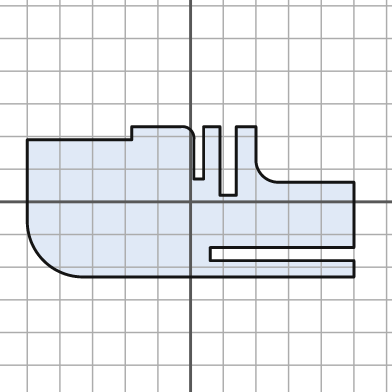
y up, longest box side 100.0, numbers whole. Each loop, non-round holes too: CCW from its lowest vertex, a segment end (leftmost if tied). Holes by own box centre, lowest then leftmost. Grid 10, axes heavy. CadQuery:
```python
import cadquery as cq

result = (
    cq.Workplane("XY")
    .moveTo(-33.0, -23.0)
    .lineTo(50.0, -23.0)
    .lineTo(50.0, -18.0)
    .lineTo(6.0, -18.0)
    .lineTo(6.0, -14.0)
    .lineTo(50.0, -14.0)
    .lineTo(50.0, 6.0)
    .lineTo(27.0, 6.0)
    .threePointArc((22.0, 8.0), (20.0, 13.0))
    .lineTo(20.0, 23.0)
    .lineTo(14.0, 23.0)
    .lineTo(14.0, 2.0)
    .lineTo(9.0, 2.0)
    .lineTo(9.0, 23.0)
    .lineTo(4.0, 23.0)
    .lineTo(4.0, 7.0)
    .lineTo(1.0, 7.0)
    .lineTo(1.0, 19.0)
    .threePointArc((0.0, 22.0), (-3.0, 23.0))
    .lineTo(-18.0, 23.0)
    .lineTo(-18.0, 19.0)
    .lineTo(-50.0, 19.0)
    .lineTo(-50.0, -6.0)
    .threePointArc((-45.0, -18.0), (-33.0, -23.0))
    .close()
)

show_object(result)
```